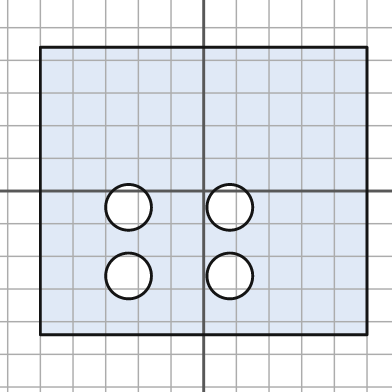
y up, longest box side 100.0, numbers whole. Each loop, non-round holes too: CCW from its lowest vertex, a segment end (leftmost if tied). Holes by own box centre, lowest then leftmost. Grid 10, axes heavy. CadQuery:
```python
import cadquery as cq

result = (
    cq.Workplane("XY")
    .moveTo(-50.0, -44.0)
    .lineTo(50.0, -44.0)
    .lineTo(50.0, 44.0)
    .lineTo(-50.0, 44.0)
    .close()
    .moveTo(-23.0, -26.0)
    .circle(7.0)
    .moveTo(8.0, -26.0)
    .circle(7.0)
    .moveTo(-23.0, -5.0)
    .circle(7.0)
    .moveTo(8.0, -5.0)
    .circle(7.0)
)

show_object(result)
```